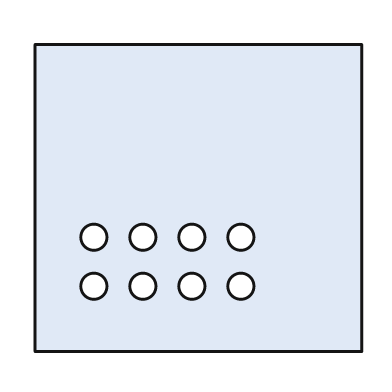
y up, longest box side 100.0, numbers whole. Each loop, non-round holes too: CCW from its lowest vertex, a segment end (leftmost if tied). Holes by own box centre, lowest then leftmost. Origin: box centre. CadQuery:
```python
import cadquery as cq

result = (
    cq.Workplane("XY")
    .moveTo(-50.0, -47.0)
    .lineTo(50.0, -47.0)
    .lineTo(50.0, 47.0)
    .lineTo(-50.0, 47.0)
    .close()
    .moveTo(-32.0, -27.0)
    .circle(4.0)
    .moveTo(-17.0, -27.0)
    .circle(4.0)
    .moveTo(-2.0, -27.0)
    .circle(4.0)
    .moveTo(13.0, -27.0)
    .circle(4.0)
    .moveTo(-32.0, -12.0)
    .circle(4.0)
    .moveTo(-17.0, -12.0)
    .circle(4.0)
    .moveTo(-2.0, -12.0)
    .circle(4.0)
    .moveTo(13.0, -12.0)
    .circle(4.0)
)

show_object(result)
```